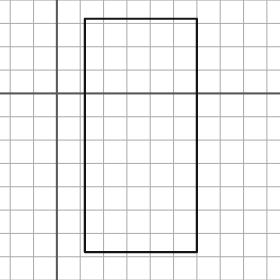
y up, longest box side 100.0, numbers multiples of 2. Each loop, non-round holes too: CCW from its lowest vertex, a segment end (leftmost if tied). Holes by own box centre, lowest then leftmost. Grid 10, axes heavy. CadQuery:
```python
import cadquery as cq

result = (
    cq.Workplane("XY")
    .moveTo(12.0, -68.0)
    .lineTo(60.0, -68.0)
    .lineTo(60.0, 32.0)
    .lineTo(12.0, 32.0)
    .close()
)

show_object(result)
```